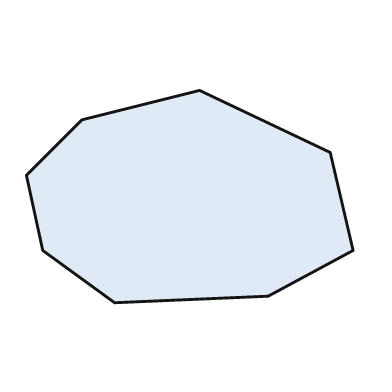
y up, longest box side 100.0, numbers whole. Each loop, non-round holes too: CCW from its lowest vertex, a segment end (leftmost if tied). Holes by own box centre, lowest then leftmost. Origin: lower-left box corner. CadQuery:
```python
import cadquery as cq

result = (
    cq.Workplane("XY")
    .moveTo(27.0, 0.0)
    .lineTo(74.0, 2.0)
    .lineTo(100.0, 16.0)
    .lineTo(93.0, 46.0)
    .lineTo(53.0, 65.0)
    .lineTo(17.0, 56.0)
    .lineTo(0.0, 39.0)
    .lineTo(5.0, 16.0)
    .close()
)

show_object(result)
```